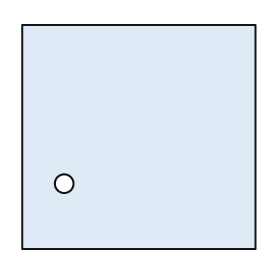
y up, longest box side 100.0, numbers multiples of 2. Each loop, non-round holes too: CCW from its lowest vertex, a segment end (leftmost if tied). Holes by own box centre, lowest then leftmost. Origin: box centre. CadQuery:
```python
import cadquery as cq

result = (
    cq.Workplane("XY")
    .moveTo(-50.0, -48.0)
    .lineTo(50.0, -48.0)
    .lineTo(50.0, 48.0)
    .lineTo(-50.0, 48.0)
    .close()
    .moveTo(-32.0, -20.0)
    .circle(4.0)
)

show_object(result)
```